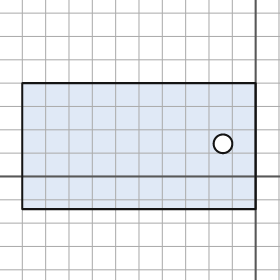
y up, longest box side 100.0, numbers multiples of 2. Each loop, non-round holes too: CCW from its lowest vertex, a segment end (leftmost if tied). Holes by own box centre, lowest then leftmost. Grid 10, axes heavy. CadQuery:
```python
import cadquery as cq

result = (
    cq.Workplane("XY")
    .moveTo(-100.0, -14.0)
    .lineTo(0.0, -14.0)
    .lineTo(0.0, 40.0)
    .lineTo(-100.0, 40.0)
    .close()
    .moveTo(-14.0, 14.0)
    .circle(4.0)
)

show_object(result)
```